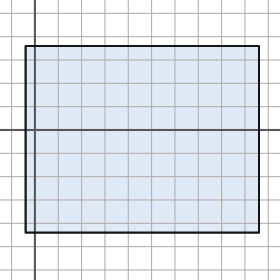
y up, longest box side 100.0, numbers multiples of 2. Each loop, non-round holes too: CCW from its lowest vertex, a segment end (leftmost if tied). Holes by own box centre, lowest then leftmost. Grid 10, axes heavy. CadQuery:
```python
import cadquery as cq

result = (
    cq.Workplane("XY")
    .moveTo(-4.0, -44.0)
    .lineTo(96.0, -44.0)
    .lineTo(96.0, 36.0)
    .lineTo(-4.0, 36.0)
    .close()
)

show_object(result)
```